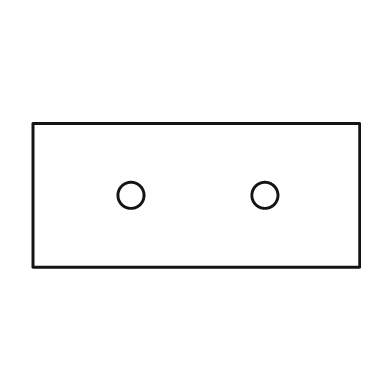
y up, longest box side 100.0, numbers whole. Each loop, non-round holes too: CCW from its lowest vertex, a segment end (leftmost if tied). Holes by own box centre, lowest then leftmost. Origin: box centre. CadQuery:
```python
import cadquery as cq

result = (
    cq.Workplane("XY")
    .moveTo(-50.0, -22.0)
    .lineTo(50.0, -22.0)
    .lineTo(50.0, 22.0)
    .lineTo(-50.0, 22.0)
    .close()
    .moveTo(-20.0, 0.0)
    .circle(4.0)
    .moveTo(21.0, 0.0)
    .circle(4.0)
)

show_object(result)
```